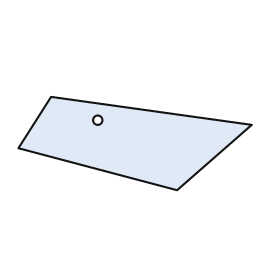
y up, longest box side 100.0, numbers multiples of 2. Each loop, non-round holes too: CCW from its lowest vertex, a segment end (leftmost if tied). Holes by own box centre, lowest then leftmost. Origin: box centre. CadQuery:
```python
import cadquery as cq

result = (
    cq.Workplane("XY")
    .moveTo(18.0, -20.0)
    .lineTo(50.0, 8.0)
    .lineTo(-36.0, 20.0)
    .lineTo(-50.0, -2.0)
    .close()
    .moveTo(-16.0, 10.0)
    .circle(2.0)
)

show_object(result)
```